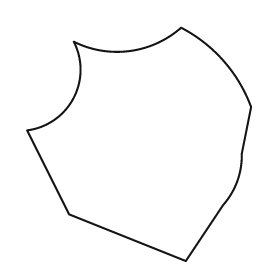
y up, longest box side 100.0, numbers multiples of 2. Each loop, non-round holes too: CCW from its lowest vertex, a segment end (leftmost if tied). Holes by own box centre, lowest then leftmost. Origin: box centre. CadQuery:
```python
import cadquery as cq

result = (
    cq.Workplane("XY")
    .moveTo(20.0, -50.0)
    .lineTo(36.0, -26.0)
    .threePointArc((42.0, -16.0), (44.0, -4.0))
    .lineTo(48.0, 16.0)
    .threePointArc((36.0, 36.0), (18.0, 50.0))
    .threePointArc((-4.0, 40.0), (-28.0, 44.0))
    .threePointArc((-28.0, 20.0), (-48.0, 6.0))
    .lineTo(-30.0, -30.0)
    .close()
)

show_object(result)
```